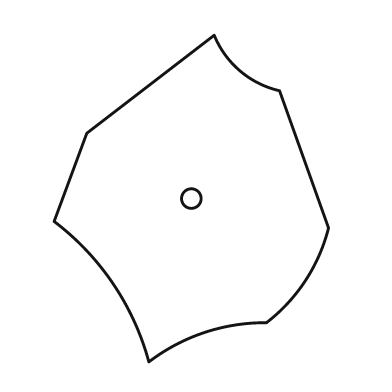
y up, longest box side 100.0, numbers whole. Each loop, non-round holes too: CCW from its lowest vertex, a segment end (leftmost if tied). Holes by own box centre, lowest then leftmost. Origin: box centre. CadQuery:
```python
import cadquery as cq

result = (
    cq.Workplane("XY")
    .moveTo(-13.0, -50.0)
    .threePointArc((4.0, -41.0), (23.0, -38.0))
    .threePointArc((35.0, -25.0), (42.0, -9.0))
    .lineTo(27.0, 33.0)
    .threePointArc((15.0, 39.0), (7.0, 50.0))
    .lineTo(-32.0, 20.0)
    .lineTo(-42.0, -7.0)
    .threePointArc((-24.0, -26.0), (-13.0, -50.0))
    .close()
    .moveTo(0.0, 0.0)
    .circle(3.0)
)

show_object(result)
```